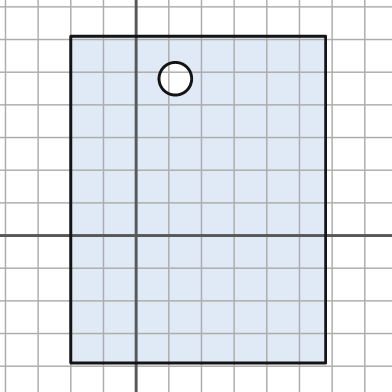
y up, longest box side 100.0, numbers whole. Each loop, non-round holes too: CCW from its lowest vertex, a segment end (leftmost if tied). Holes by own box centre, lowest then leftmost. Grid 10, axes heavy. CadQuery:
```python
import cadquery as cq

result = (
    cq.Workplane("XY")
    .moveTo(-20.0, -39.0)
    .lineTo(58.0, -39.0)
    .lineTo(58.0, 61.0)
    .lineTo(-20.0, 61.0)
    .close()
    .moveTo(12.0, 48.0)
    .circle(5.0)
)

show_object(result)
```